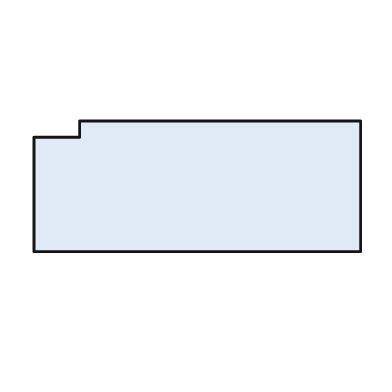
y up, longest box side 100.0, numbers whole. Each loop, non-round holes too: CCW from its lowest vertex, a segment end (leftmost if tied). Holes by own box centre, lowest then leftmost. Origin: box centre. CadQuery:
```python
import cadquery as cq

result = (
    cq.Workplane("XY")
    .moveTo(-50.0, -20.0)
    .lineTo(50.0, -20.0)
    .lineTo(50.0, 20.0)
    .lineTo(-36.0, 20.0)
    .lineTo(-36.0, 15.0)
    .lineTo(-50.0, 15.0)
    .close()
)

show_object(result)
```